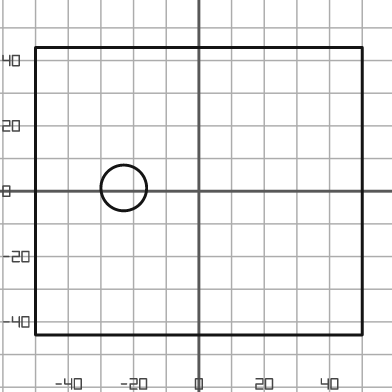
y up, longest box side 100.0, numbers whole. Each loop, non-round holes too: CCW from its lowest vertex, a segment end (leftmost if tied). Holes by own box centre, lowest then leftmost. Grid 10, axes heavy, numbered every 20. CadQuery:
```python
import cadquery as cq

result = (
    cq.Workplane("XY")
    .moveTo(-50.0, -44.0)
    .lineTo(50.0, -44.0)
    .lineTo(50.0, 44.0)
    .lineTo(-50.0, 44.0)
    .close()
    .moveTo(-23.0, 1.0)
    .circle(7.0)
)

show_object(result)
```